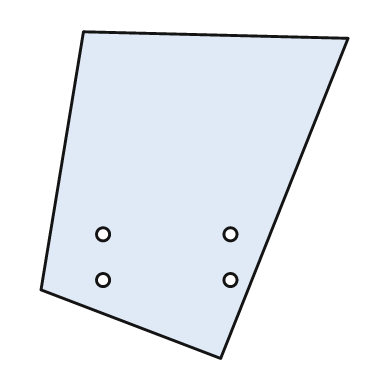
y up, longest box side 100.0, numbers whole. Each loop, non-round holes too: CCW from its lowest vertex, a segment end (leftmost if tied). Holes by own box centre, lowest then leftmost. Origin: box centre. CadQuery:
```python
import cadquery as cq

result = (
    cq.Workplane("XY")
    .moveTo(8.0, -50.0)
    .lineTo(47.0, 48.0)
    .lineTo(-34.0, 50.0)
    .lineTo(-47.0, -29.0)
    .close()
    .moveTo(-28.0, -26.0)
    .circle(2.0)
    .moveTo(11.0, -26.0)
    .circle(2.0)
    .moveTo(-28.0, -12.0)
    .circle(2.0)
    .moveTo(11.0, -12.0)
    .circle(2.0)
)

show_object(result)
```